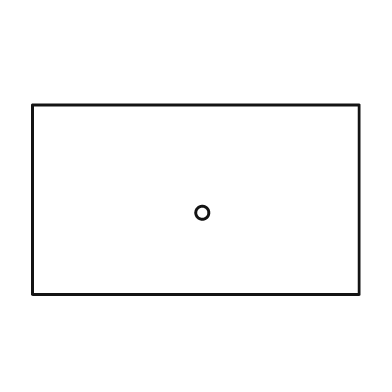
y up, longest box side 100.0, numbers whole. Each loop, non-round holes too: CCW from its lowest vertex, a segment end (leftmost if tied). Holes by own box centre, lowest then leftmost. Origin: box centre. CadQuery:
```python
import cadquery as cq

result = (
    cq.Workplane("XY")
    .moveTo(-50.0, -29.0)
    .lineTo(50.0, -29.0)
    .lineTo(50.0, 29.0)
    .lineTo(-50.0, 29.0)
    .close()
    .moveTo(2.0, -4.0)
    .circle(2.0)
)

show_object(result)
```